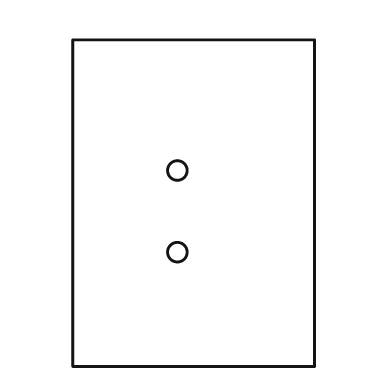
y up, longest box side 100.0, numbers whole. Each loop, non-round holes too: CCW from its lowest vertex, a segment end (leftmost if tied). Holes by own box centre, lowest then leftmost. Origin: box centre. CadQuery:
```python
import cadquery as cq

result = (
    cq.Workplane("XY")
    .moveTo(-37.0, -50.0)
    .lineTo(37.0, -50.0)
    .lineTo(37.0, 50.0)
    .lineTo(-37.0, 50.0)
    .close()
    .moveTo(-5.0, -15.0)
    .circle(3.0)
    .moveTo(-5.0, 10.0)
    .circle(3.0)
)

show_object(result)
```